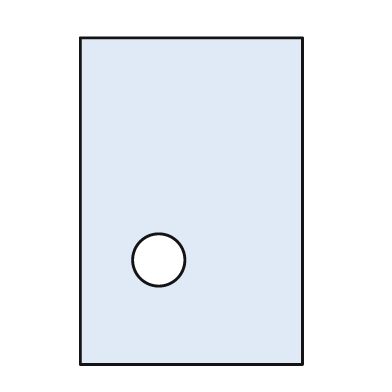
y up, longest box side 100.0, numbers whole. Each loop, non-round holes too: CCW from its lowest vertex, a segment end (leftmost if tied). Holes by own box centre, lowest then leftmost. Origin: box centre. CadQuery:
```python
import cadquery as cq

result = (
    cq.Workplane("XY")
    .moveTo(-34.0, -50.0)
    .lineTo(34.0, -50.0)
    .lineTo(34.0, 50.0)
    .lineTo(-34.0, 50.0)
    .close()
    .moveTo(-10.0, -18.0)
    .circle(8.0)
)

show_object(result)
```